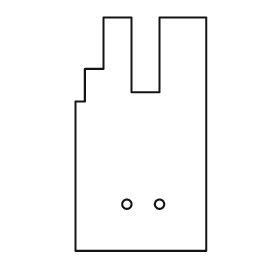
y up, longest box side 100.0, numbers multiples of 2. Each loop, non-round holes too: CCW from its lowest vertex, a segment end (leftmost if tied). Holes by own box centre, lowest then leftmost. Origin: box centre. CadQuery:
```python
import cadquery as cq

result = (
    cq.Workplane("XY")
    .moveTo(-28.0, -50.0)
    .lineTo(28.0, -50.0)
    .lineTo(28.0, 50.0)
    .lineTo(8.0, 50.0)
    .lineTo(8.0, 18.0)
    .lineTo(-4.0, 18.0)
    .lineTo(-4.0, 50.0)
    .lineTo(-16.0, 50.0)
    .lineTo(-16.0, 28.0)
    .lineTo(-24.0, 28.0)
    .lineTo(-24.0, 14.0)
    .lineTo(-28.0, 14.0)
    .close()
    .moveTo(-6.0, -30.0)
    .circle(2.0)
    .moveTo(8.0, -30.0)
    .circle(2.0)
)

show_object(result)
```